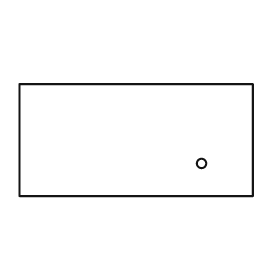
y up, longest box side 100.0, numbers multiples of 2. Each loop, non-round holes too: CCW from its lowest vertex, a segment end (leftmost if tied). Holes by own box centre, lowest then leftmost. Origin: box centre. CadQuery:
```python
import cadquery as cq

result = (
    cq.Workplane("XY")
    .moveTo(-50.0, -24.0)
    .lineTo(50.0, -24.0)
    .lineTo(50.0, 24.0)
    .lineTo(-50.0, 24.0)
    .close()
    .moveTo(28.0, -10.0)
    .circle(2.0)
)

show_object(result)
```